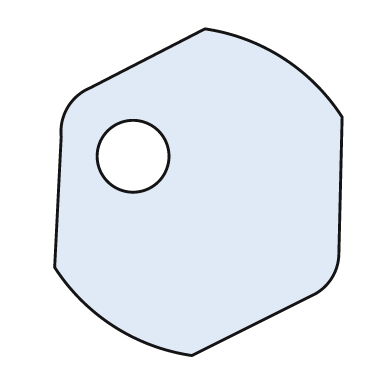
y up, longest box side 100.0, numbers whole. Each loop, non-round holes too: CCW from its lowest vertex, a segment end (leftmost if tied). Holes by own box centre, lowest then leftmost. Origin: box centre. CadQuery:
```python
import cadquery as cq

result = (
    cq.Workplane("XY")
    .moveTo(-2.0, -50.0)
    .lineTo(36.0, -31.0)
    .threePointArc((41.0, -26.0), (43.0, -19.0))
    .lineTo(44.0, 23.0)
    .threePointArc((26.0, 41.0), (2.0, 50.0))
    .lineTo(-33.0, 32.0)
    .threePointArc((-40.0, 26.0), (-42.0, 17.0))
    .lineTo(-44.0, -23.0)
    .threePointArc((-26.0, -41.0), (-2.0, -50.0))
    .close()
    .moveTo(-20.0, 11.0)
    .circle(11.0)
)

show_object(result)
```